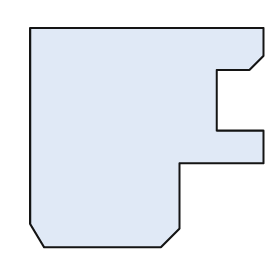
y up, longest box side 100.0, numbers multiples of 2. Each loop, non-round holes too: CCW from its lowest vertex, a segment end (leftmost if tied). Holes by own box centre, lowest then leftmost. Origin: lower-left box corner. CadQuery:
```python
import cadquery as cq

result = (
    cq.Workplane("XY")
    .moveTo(6.0, 0.0)
    .lineTo(56.0, 0.0)
    .lineTo(64.0, 8.0)
    .lineTo(64.0, 36.0)
    .lineTo(100.0, 36.0)
    .lineTo(100.0, 50.0)
    .lineTo(80.0, 50.0)
    .lineTo(80.0, 76.0)
    .lineTo(94.0, 76.0)
    .lineTo(100.0, 82.0)
    .lineTo(100.0, 94.0)
    .lineTo(0.0, 94.0)
    .lineTo(0.0, 10.0)
    .close()
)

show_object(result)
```